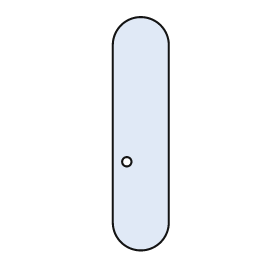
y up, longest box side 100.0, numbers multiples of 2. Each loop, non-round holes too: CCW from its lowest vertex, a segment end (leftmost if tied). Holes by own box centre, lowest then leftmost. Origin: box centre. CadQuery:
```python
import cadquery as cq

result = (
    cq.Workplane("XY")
    .moveTo(-12.0, -38.0)
    .threePointArc((0.0, -50.0), (12.0, -38.0))
    .lineTo(12.0, 38.0)
    .threePointArc((0.0, 50.0), (-12.0, 38.0))
    .close()
    .moveTo(-6.0, -12.0)
    .circle(2.0)
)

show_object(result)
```